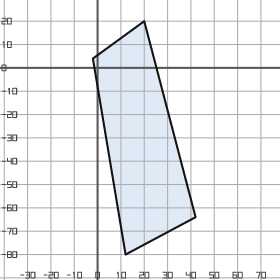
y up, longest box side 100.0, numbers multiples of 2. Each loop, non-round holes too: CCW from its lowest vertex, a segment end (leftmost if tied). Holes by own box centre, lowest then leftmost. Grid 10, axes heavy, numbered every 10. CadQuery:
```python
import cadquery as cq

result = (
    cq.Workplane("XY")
    .moveTo(12.0, -80.0)
    .lineTo(42.0, -64.0)
    .lineTo(20.0, 20.0)
    .lineTo(-2.0, 4.0)
    .close()
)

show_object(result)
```